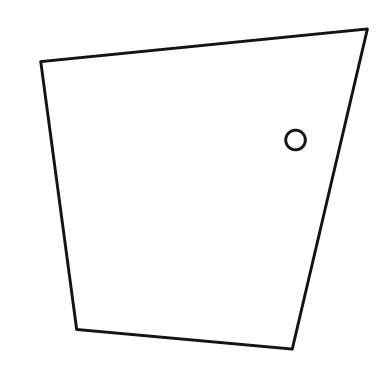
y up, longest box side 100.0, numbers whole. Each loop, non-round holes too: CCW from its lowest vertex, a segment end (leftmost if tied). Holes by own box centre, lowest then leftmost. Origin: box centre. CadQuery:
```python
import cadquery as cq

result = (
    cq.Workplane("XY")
    .moveTo(27.0, -49.0)
    .lineTo(50.0, 49.0)
    .lineTo(-50.0, 39.0)
    .lineTo(-39.0, -43.0)
    .close()
    .moveTo(28.0, 15.0)
    .circle(3.0)
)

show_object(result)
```